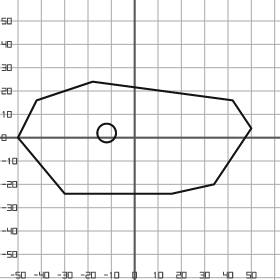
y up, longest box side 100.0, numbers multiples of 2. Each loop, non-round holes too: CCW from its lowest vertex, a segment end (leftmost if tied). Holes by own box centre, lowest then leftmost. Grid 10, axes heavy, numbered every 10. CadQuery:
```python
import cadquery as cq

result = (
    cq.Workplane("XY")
    .moveTo(-30.0, -24.0)
    .lineTo(16.0, -24.0)
    .lineTo(34.0, -20.0)
    .lineTo(50.0, 4.0)
    .lineTo(42.0, 16.0)
    .lineTo(-18.0, 24.0)
    .lineTo(-42.0, 16.0)
    .lineTo(-50.0, 0.0)
    .close()
    .moveTo(-12.0, 2.0)
    .circle(4.0)
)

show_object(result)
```